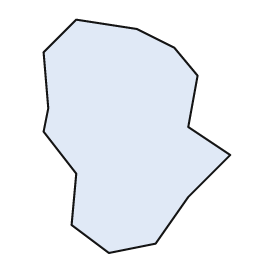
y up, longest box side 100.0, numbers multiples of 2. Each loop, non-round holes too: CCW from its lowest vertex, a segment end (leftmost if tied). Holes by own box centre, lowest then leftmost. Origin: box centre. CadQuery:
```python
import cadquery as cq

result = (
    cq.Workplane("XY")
    .moveTo(-12.0, -50.0)
    .lineTo(8.0, -46.0)
    .lineTo(22.0, -26.0)
    .lineTo(40.0, -8.0)
    .lineTo(22.0, 4.0)
    .lineTo(26.0, 26.0)
    .lineTo(16.0, 38.0)
    .lineTo(0.0, 46.0)
    .lineTo(-26.0, 50.0)
    .lineTo(-40.0, 36.0)
    .lineTo(-38.0, 12.0)
    .lineTo(-40.0, 2.0)
    .lineTo(-26.0, -16.0)
    .lineTo(-28.0, -38.0)
    .close()
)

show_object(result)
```